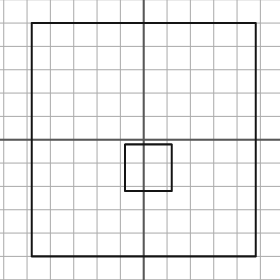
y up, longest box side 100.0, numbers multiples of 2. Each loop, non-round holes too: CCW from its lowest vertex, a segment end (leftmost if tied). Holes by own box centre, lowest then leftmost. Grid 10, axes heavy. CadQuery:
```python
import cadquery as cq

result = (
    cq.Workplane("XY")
    .moveTo(-48.0, -50.0)
    .lineTo(48.0, -50.0)
    .lineTo(48.0, 50.0)
    .lineTo(-48.0, 50.0)
    .close()
    .moveTo(-8.0, -22.0)
    .lineTo(12.0, -22.0)
    .lineTo(12.0, -2.0)
    .lineTo(-8.0, -2.0)
    .close()
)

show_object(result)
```